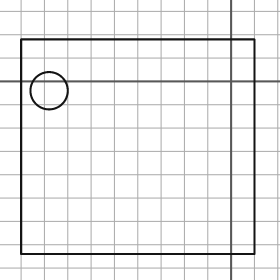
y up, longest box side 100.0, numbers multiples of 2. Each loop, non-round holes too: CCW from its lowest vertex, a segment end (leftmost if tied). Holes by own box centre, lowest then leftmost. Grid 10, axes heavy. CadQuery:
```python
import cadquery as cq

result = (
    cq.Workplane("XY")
    .moveTo(-90.0, -74.0)
    .lineTo(10.0, -74.0)
    .lineTo(10.0, 18.0)
    .lineTo(-90.0, 18.0)
    .close()
    .moveTo(-78.0, -4.0)
    .circle(8.0)
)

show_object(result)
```